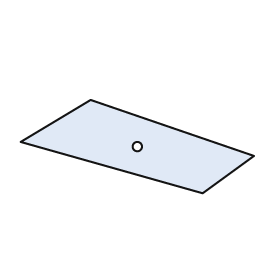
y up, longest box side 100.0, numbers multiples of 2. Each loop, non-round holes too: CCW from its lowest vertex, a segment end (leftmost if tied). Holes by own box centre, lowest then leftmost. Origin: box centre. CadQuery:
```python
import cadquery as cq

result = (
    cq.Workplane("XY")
    .moveTo(28.0, -20.0)
    .lineTo(50.0, -4.0)
    .lineTo(-20.0, 20.0)
    .lineTo(-50.0, 2.0)
    .close()
    .moveTo(0.0, 0.0)
    .circle(2.0)
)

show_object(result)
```